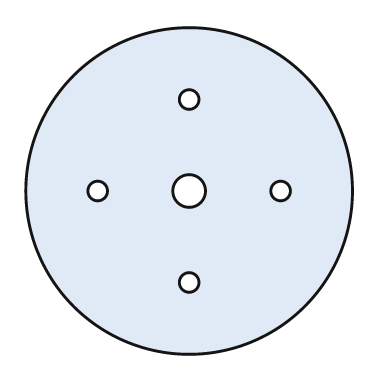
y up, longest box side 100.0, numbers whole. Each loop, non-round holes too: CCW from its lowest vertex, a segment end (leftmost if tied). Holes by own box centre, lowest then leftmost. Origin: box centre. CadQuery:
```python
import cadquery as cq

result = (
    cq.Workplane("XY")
    .moveTo(0.0, 0.0)
    .circle(50.0)
    .moveTo(0.0, -28.0)
    .circle(3.0)
    .moveTo(-28.0, 0.0)
    .circle(3.0)
    .moveTo(0.0, 0.0)
    .circle(5.0)
    .moveTo(28.0, 0.0)
    .circle(3.0)
    .moveTo(0.0, 28.0)
    .circle(3.0)
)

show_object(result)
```